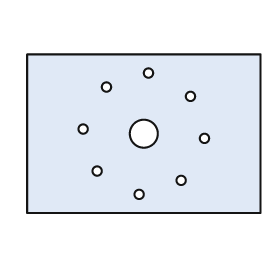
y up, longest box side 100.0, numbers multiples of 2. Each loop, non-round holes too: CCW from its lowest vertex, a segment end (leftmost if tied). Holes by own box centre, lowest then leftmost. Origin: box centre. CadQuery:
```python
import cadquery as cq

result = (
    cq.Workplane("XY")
    .moveTo(-50.0, -34.0)
    .lineTo(50.0, -34.0)
    .lineTo(50.0, 34.0)
    .lineTo(-50.0, 34.0)
    .close()
    .moveTo(-2.0, -26.0)
    .circle(2.0)
    .moveTo(16.0, -20.0)
    .circle(2.0)
    .moveTo(-20.0, -16.0)
    .circle(2.0)
    .moveTo(26.0, -2.0)
    .circle(2.0)
    .moveTo(0.0, 0.0)
    .circle(6.0)
    .moveTo(-26.0, 2.0)
    .circle(2.0)
    .moveTo(20.0, 16.0)
    .circle(2.0)
    .moveTo(-16.0, 20.0)
    .circle(2.0)
    .moveTo(2.0, 26.0)
    .circle(2.0)
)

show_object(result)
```